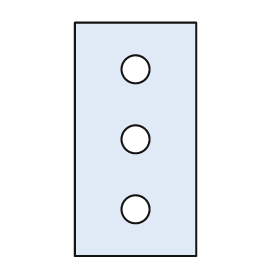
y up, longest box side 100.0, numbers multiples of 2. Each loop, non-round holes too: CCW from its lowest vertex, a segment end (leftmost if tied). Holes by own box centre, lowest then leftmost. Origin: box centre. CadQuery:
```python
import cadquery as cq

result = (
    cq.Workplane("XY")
    .moveTo(-26.0, -50.0)
    .lineTo(26.0, -50.0)
    .lineTo(26.0, 50.0)
    .lineTo(-26.0, 50.0)
    .close()
    .moveTo(0.0, -30.0)
    .circle(6.0)
    .moveTo(0.0, 0.0)
    .circle(6.0)
    .moveTo(0.0, 30.0)
    .circle(6.0)
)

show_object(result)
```